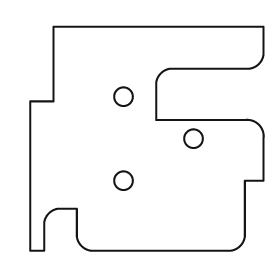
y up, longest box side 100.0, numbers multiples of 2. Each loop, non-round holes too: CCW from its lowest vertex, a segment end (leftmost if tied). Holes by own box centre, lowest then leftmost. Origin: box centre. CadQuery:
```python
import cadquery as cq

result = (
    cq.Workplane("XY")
    .moveTo(-50.0, -48.0)
    .lineTo(-44.0, -48.0)
    .lineTo(-44.0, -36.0)
    .threePointArc((-42.0, -32.0), (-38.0, -30.0))
    .lineTo(-30.0, -30.0)
    .lineTo(-30.0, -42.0)
    .threePointArc((-28.0, -46.0), (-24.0, -48.0))
    .lineTo(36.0, -48.0)
    .threePointArc((40.0, -46.0), (42.0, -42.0))
    .lineTo(42.0, -18.0)
    .lineTo(50.0, -18.0)
    .lineTo(50.0, 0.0)
    .threePointArc((48.0, 6.0), (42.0, 8.0))
    .lineTo(4.0, 8.0)
    .lineTo(4.0, 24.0)
    .threePointArc((6.0, 28.0), (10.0, 30.0))
    .lineTo(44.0, 30.0)
    .threePointArc((48.0, 32.0), (50.0, 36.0))
    .lineTo(50.0, 48.0)
    .lineTo(-40.0, 48.0)
    .lineTo(-40.0, 16.0)
    .lineTo(-50.0, 16.0)
    .close()
    .moveTo(-10.0, -18.0)
    .circle(4.0)
    .moveTo(20.0, 0.0)
    .circle(4.0)
    .moveTo(-10.0, 18.0)
    .circle(4.0)
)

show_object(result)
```